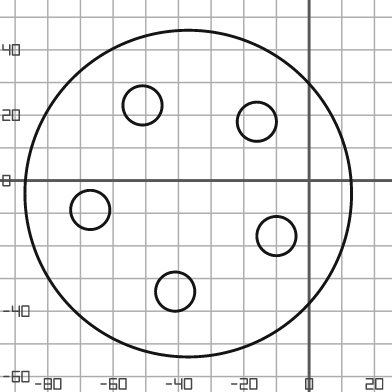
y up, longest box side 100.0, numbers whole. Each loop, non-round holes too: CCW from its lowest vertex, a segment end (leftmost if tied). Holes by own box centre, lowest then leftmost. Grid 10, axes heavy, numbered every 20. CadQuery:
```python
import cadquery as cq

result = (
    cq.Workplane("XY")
    .moveTo(-37.0, -4.0)
    .circle(50.0)
    .moveTo(-41.0, -34.0)
    .circle(6.0)
    .moveTo(-10.0, -17.0)
    .circle(6.0)
    .moveTo(-67.0, -9.0)
    .circle(6.0)
    .moveTo(-16.0, 18.0)
    .circle(6.0)
    .moveTo(-51.0, 23.0)
    .circle(6.0)
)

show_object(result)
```